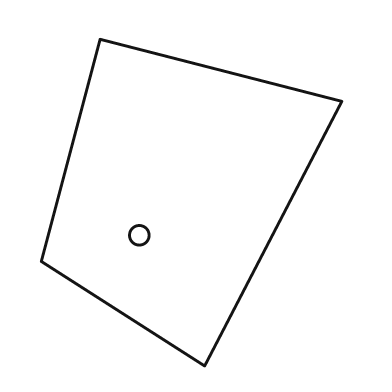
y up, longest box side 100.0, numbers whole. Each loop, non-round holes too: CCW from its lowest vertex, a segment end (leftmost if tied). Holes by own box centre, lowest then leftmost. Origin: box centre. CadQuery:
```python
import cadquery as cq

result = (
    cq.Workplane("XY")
    .moveTo(4.0, -50.0)
    .lineTo(46.0, 31.0)
    .lineTo(-28.0, 50.0)
    .lineTo(-46.0, -18.0)
    .close()
    .moveTo(-16.0, -10.0)
    .circle(3.0)
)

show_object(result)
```